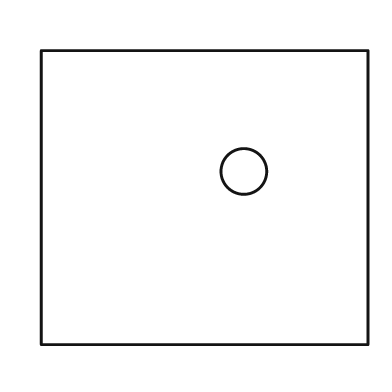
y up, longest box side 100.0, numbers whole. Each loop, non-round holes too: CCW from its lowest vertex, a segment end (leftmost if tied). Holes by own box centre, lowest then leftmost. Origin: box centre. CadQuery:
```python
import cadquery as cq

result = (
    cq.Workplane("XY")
    .moveTo(-50.0, -45.0)
    .lineTo(50.0, -45.0)
    .lineTo(50.0, 45.0)
    .lineTo(-50.0, 45.0)
    .close()
    .moveTo(12.0, 8.0)
    .circle(7.0)
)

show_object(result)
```